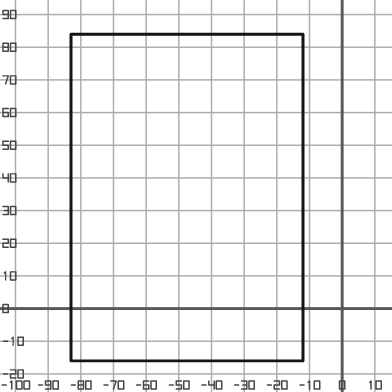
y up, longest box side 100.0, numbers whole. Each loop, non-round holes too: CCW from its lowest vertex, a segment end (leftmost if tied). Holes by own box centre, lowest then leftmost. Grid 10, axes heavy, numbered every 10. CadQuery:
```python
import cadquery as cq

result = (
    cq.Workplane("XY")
    .moveTo(-83.0, -16.0)
    .lineTo(-12.0, -16.0)
    .lineTo(-12.0, 84.0)
    .lineTo(-83.0, 84.0)
    .close()
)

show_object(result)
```